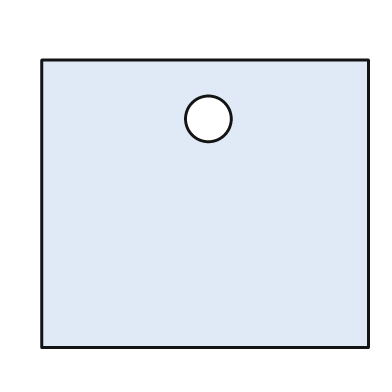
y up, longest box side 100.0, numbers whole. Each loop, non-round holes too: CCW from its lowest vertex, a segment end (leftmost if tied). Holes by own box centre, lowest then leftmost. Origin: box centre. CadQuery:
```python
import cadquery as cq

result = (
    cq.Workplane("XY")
    .moveTo(-50.0, -44.0)
    .lineTo(50.0, -44.0)
    .lineTo(50.0, 44.0)
    .lineTo(-50.0, 44.0)
    .close()
    .moveTo(1.0, 26.0)
    .circle(7.0)
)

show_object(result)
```